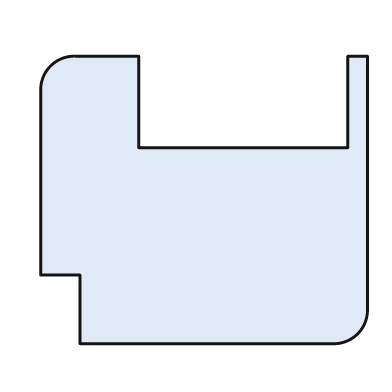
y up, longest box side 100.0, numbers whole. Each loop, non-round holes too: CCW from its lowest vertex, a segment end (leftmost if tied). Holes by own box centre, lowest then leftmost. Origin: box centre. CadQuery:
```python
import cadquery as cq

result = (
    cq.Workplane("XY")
    .moveTo(-38.0, -44.0)
    .lineTo(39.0, -44.0)
    .threePointArc((47.0, -41.0), (50.0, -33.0))
    .lineTo(50.0, 44.0)
    .lineTo(44.0, 44.0)
    .lineTo(44.0, 16.0)
    .lineTo(-20.0, 16.0)
    .lineTo(-20.0, 44.0)
    .lineTo(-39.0, 44.0)
    .threePointArc((-47.0, 41.0), (-50.0, 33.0))
    .lineTo(-50.0, -23.0)
    .lineTo(-38.0, -23.0)
    .close()
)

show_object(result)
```